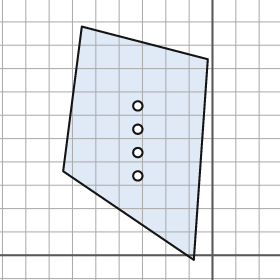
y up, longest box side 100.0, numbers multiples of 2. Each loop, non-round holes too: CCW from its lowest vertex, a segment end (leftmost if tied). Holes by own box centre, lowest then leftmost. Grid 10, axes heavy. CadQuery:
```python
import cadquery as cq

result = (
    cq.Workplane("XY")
    .moveTo(-8.0, -2.0)
    .lineTo(-2.0, 84.0)
    .lineTo(-56.0, 98.0)
    .lineTo(-64.0, 36.0)
    .close()
    .moveTo(-32.0, 34.0)
    .circle(2.0)
    .moveTo(-32.0, 44.0)
    .circle(2.0)
    .moveTo(-32.0, 54.0)
    .circle(2.0)
    .moveTo(-32.0, 64.0)
    .circle(2.0)
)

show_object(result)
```